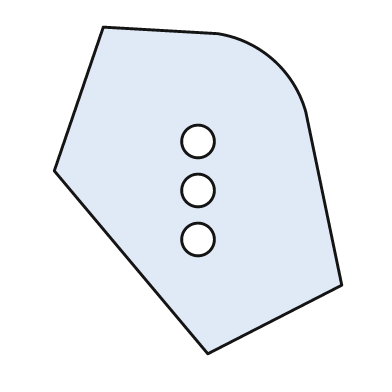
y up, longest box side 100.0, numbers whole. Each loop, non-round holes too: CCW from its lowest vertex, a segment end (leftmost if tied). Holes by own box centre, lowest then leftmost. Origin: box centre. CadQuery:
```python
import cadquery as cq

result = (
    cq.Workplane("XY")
    .moveTo(3.0, -50.0)
    .lineTo(44.0, -29.0)
    .lineTo(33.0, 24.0)
    .threePointArc((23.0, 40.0), (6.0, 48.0))
    .lineTo(-29.0, 50.0)
    .lineTo(-44.0, 6.0)
    .close()
    .moveTo(0.0, -15.0)
    .circle(5.0)
    .moveTo(0.0, 0.0)
    .circle(5.0)
    .moveTo(0.0, 15.0)
    .circle(5.0)
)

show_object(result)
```